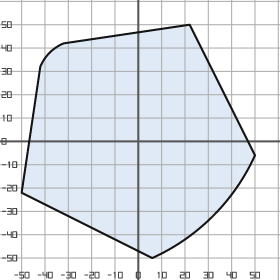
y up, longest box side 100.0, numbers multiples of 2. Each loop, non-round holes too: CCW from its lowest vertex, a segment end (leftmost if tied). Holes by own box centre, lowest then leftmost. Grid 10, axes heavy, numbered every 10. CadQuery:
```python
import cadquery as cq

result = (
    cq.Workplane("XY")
    .moveTo(6.0, -50.0)
    .threePointArc((32.0, -32.0), (50.0, -6.0))
    .lineTo(22.0, 50.0)
    .lineTo(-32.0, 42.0)
    .threePointArc((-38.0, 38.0), (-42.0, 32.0))
    .lineTo(-50.0, -22.0)
    .close()
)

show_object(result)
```